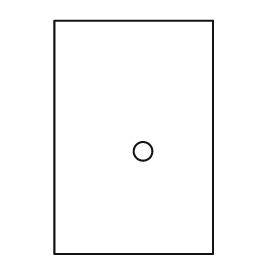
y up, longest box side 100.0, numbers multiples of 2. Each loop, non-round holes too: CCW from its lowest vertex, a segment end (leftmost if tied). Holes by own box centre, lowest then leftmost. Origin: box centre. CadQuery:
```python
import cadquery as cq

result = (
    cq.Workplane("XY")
    .moveTo(-34.0, -50.0)
    .lineTo(34.0, -50.0)
    .lineTo(34.0, 50.0)
    .lineTo(-34.0, 50.0)
    .close()
    .moveTo(4.0, -6.0)
    .circle(4.0)
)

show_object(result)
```